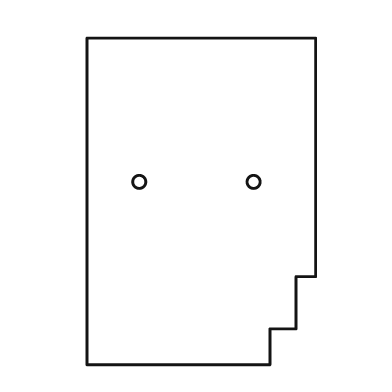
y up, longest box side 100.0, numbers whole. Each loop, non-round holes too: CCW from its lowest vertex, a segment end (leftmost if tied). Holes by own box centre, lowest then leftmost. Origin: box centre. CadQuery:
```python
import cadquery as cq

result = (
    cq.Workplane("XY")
    .moveTo(-35.0, -50.0)
    .lineTo(21.0, -50.0)
    .lineTo(21.0, -39.0)
    .lineTo(29.0, -39.0)
    .lineTo(29.0, -23.0)
    .lineTo(35.0, -23.0)
    .lineTo(35.0, 50.0)
    .lineTo(-35.0, 50.0)
    .close()
    .moveTo(-19.0, 6.0)
    .circle(2.0)
    .moveTo(16.0, 6.0)
    .circle(2.0)
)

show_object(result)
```